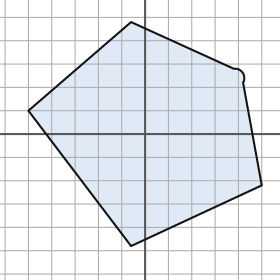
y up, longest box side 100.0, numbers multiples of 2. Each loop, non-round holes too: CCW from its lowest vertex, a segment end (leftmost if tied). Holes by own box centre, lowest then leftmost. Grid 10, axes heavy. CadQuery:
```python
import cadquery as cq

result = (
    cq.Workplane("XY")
    .moveTo(-6.0, -48.0)
    .lineTo(50.0, -22.0)
    .lineTo(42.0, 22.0)
    .threePointArc((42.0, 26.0), (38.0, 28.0))
    .lineTo(-6.0, 48.0)
    .lineTo(-50.0, 10.0)
    .close()
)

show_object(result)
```